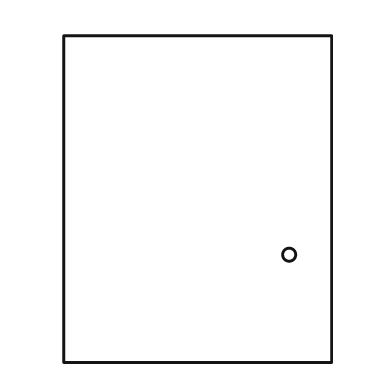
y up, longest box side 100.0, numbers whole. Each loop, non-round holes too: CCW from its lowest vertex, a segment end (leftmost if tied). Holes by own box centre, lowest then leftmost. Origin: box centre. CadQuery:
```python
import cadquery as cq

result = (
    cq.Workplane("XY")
    .moveTo(-41.0, -50.0)
    .lineTo(41.0, -50.0)
    .lineTo(41.0, 50.0)
    .lineTo(-41.0, 50.0)
    .close()
    .moveTo(28.0, -17.0)
    .circle(2.0)
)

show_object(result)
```